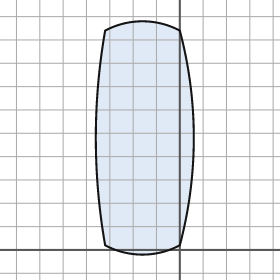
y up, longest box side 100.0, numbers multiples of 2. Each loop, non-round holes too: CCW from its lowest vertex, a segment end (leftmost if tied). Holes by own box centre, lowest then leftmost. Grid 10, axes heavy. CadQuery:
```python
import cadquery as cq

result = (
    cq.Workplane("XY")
    .moveTo(-32.0, 2.0)
    .threePointArc((-16.0, -2.0), (0.0, 2.0))
    .threePointArc((6.0, 48.0), (0.0, 94.0))
    .threePointArc((-16.0, 98.0), (-32.0, 94.0))
    .threePointArc((-36.0, 48.0), (-32.0, 2.0))
    .close()
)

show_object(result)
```